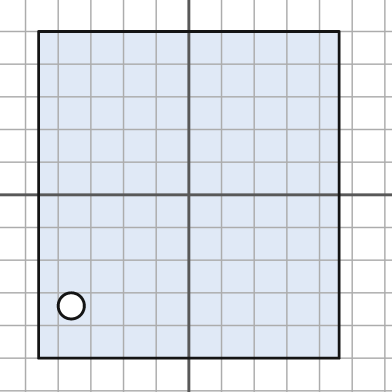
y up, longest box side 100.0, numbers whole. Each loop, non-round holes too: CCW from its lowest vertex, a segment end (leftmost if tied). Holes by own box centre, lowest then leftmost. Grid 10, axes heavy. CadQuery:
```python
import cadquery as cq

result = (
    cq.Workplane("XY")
    .moveTo(-46.0, -50.0)
    .lineTo(46.0, -50.0)
    .lineTo(46.0, 50.0)
    .lineTo(-46.0, 50.0)
    .close()
    .moveTo(-36.0, -34.0)
    .circle(4.0)
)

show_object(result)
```